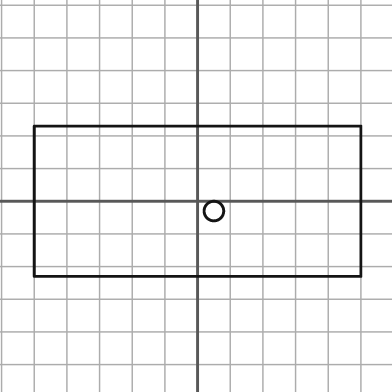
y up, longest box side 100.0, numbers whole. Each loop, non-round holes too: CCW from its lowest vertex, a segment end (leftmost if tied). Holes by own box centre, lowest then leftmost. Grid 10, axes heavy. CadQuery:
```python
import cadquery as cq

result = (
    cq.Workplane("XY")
    .moveTo(-50.0, -23.0)
    .lineTo(50.0, -23.0)
    .lineTo(50.0, 23.0)
    .lineTo(-50.0, 23.0)
    .close()
    .moveTo(5.0, -3.0)
    .circle(3.0)
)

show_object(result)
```